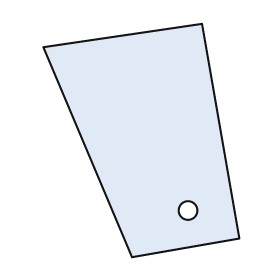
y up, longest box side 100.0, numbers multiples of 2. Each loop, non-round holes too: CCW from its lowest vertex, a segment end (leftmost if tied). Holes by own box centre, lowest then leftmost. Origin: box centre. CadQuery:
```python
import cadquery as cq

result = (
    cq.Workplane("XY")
    .moveTo(-4.0, -50.0)
    .lineTo(42.0, -42.0)
    .lineTo(26.0, 50.0)
    .lineTo(-42.0, 40.0)
    .close()
    .moveTo(20.0, -30.0)
    .circle(4.0)
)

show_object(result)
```